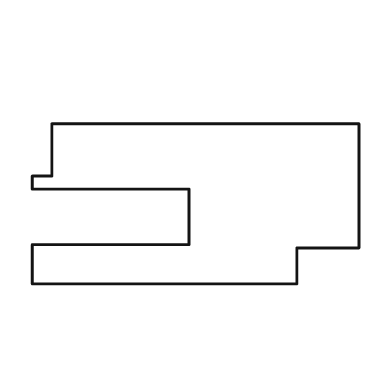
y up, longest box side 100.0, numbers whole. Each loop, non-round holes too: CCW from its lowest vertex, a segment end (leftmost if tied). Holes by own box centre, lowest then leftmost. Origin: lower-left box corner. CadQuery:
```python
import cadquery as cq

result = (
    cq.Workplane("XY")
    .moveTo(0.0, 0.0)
    .lineTo(81.0, 0.0)
    .lineTo(81.0, 11.0)
    .lineTo(100.0, 11.0)
    .lineTo(100.0, 49.0)
    .lineTo(6.0, 49.0)
    .lineTo(6.0, 33.0)
    .lineTo(0.0, 33.0)
    .lineTo(0.0, 29.0)
    .lineTo(48.0, 29.0)
    .lineTo(48.0, 12.0)
    .lineTo(0.0, 12.0)
    .close()
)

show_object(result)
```